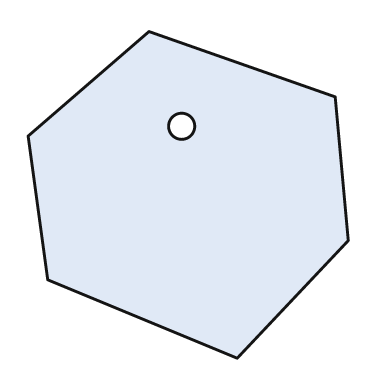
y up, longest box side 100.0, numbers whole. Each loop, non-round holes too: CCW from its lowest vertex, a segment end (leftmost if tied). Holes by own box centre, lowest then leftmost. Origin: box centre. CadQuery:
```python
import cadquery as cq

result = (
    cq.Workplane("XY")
    .moveTo(15.0, -50.0)
    .lineTo(49.0, -14.0)
    .lineTo(45.0, 30.0)
    .lineTo(-12.0, 50.0)
    .lineTo(-49.0, 18.0)
    .lineTo(-43.0, -26.0)
    .close()
    .moveTo(-2.0, 21.0)
    .circle(4.0)
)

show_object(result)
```